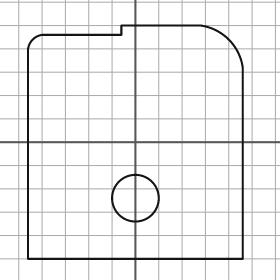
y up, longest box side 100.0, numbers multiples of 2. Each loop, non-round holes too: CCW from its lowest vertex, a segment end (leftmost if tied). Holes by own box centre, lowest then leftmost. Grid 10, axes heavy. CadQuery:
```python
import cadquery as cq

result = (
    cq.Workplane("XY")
    .moveTo(-46.0, -50.0)
    .lineTo(46.0, -50.0)
    .lineTo(46.0, 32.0)
    .threePointArc((40.0, 44.0), (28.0, 50.0))
    .lineTo(-6.0, 50.0)
    .lineTo(-6.0, 46.0)
    .lineTo(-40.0, 46.0)
    .threePointArc((-44.0, 44.0), (-46.0, 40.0))
    .close()
    .moveTo(0.0, -24.0)
    .circle(10.0)
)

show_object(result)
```